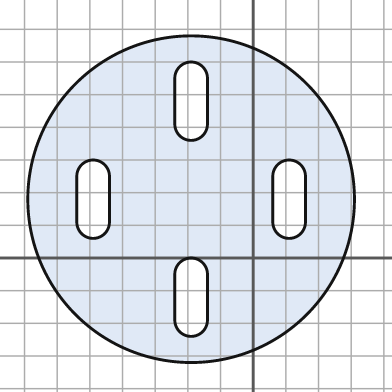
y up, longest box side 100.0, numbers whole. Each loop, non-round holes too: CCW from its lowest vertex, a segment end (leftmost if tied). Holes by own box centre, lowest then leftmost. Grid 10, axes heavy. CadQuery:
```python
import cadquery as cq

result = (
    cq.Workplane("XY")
    .moveTo(-19.0, 18.0)
    .circle(50.0)
    .moveTo(-24.0, -19.0)
    .threePointArc((-19.0, -24.0), (-14.0, -19.0))
    .lineTo(-14.0, -5.0)
    .threePointArc((-19.0, 0.0), (-24.0, -5.0))
    .close()
    .moveTo(-54.0, 11.0)
    .threePointArc((-49.0, 6.0), (-44.0, 11.0))
    .lineTo(-44.0, 25.0)
    .threePointArc((-49.0, 30.0), (-54.0, 25.0))
    .close()
    .moveTo(6.0, 11.0)
    .threePointArc((11.0, 6.0), (16.0, 11.0))
    .lineTo(16.0, 25.0)
    .threePointArc((11.0, 30.0), (6.0, 25.0))
    .close()
    .moveTo(-24.0, 41.0)
    .threePointArc((-19.0, 36.0), (-14.0, 41.0))
    .lineTo(-14.0, 55.0)
    .threePointArc((-19.0, 60.0), (-24.0, 55.0))
    .close()
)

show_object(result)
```